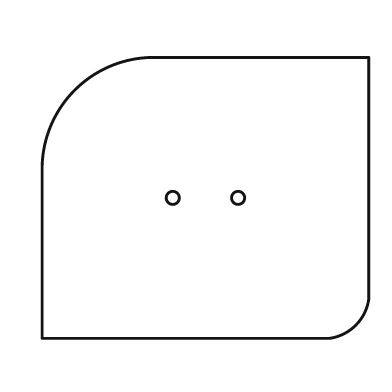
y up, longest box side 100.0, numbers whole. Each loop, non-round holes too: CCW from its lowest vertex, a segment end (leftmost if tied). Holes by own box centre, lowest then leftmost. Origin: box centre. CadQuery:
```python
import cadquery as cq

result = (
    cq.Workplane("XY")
    .moveTo(-50.0, -43.0)
    .lineTo(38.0, -43.0)
    .threePointArc((46.0, -39.0), (50.0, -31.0))
    .lineTo(50.0, 43.0)
    .lineTo(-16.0, 43.0)
    .threePointArc((-40.0, 33.0), (-50.0, 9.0))
    .close()
    .moveTo(-10.0, 0.0)
    .circle(2.0)
    .moveTo(10.0, 0.0)
    .circle(2.0)
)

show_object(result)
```